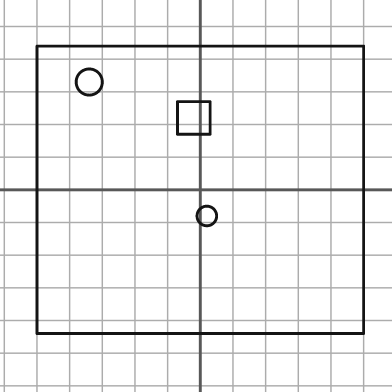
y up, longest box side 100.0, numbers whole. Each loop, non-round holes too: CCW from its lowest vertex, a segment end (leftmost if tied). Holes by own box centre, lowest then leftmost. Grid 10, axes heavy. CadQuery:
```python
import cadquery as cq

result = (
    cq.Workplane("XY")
    .moveTo(-50.0, -44.0)
    .lineTo(50.0, -44.0)
    .lineTo(50.0, 44.0)
    .lineTo(-50.0, 44.0)
    .close()
    .moveTo(2.0, -8.0)
    .circle(3.0)
    .moveTo(-7.0, 17.0)
    .lineTo(3.0, 17.0)
    .lineTo(3.0, 27.0)
    .lineTo(-7.0, 27.0)
    .close()
    .moveTo(-34.0, 33.0)
    .circle(4.0)
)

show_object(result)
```